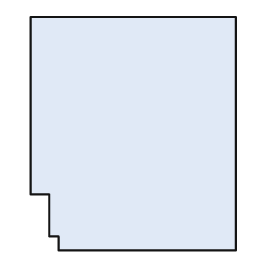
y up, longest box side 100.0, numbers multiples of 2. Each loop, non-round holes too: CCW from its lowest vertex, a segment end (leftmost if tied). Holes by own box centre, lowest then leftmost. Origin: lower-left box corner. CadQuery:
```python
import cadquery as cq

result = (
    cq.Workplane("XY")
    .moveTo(12.0, 0.0)
    .lineTo(88.0, 0.0)
    .lineTo(88.0, 100.0)
    .lineTo(0.0, 100.0)
    .lineTo(0.0, 24.0)
    .lineTo(8.0, 24.0)
    .lineTo(8.0, 6.0)
    .lineTo(12.0, 6.0)
    .close()
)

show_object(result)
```